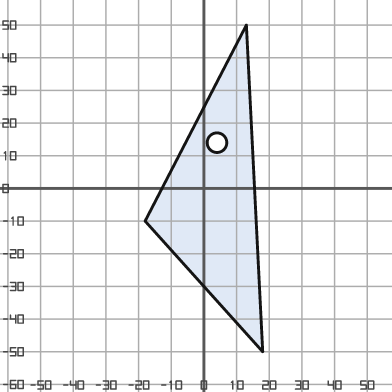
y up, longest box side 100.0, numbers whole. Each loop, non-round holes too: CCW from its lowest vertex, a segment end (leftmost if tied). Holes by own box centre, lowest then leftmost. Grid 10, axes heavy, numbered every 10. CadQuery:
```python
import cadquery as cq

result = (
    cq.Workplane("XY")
    .moveTo(18.0, -50.0)
    .lineTo(13.0, 50.0)
    .lineTo(-18.0, -10.0)
    .close()
    .moveTo(4.0, 14.0)
    .circle(3.0)
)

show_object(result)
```